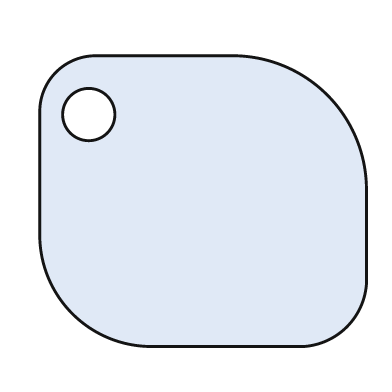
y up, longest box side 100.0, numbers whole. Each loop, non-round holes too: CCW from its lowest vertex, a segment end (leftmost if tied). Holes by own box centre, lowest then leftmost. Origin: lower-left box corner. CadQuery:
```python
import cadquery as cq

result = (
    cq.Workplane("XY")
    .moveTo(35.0, 0.0)
    .lineTo(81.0, 0.0)
    .threePointArc((94.0, 6.0), (100.0, 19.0))
    .lineTo(100.0, 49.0)
    .threePointArc((88.0, 77.0), (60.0, 89.0))
    .lineTo(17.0, 89.0)
    .threePointArc((5.0, 84.0), (0.0, 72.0))
    .lineTo(0.0, 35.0)
    .threePointArc((10.0, 10.0), (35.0, 0.0))
    .close()
    .moveTo(15.0, 71.0)
    .circle(8.0)
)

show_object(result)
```